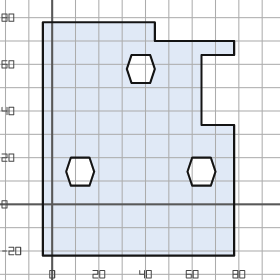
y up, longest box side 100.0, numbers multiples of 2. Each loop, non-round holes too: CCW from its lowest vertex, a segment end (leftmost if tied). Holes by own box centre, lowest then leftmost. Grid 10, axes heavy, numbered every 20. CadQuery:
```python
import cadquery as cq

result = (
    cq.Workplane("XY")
    .moveTo(-4.0, -22.0)
    .lineTo(78.0, -22.0)
    .lineTo(78.0, 34.0)
    .lineTo(64.0, 34.0)
    .lineTo(64.0, 64.0)
    .lineTo(78.0, 64.0)
    .lineTo(78.0, 70.0)
    .lineTo(44.0, 70.0)
    .lineTo(44.0, 78.0)
    .lineTo(-4.0, 78.0)
    .close()
    .moveTo(8.0, 8.0)
    .lineTo(16.0, 8.0)
    .lineTo(18.0, 14.0)
    .lineTo(16.0, 20.0)
    .lineTo(8.0, 20.0)
    .lineTo(6.0, 14.0)
    .close()
    .moveTo(60.0, 8.0)
    .lineTo(68.0, 8.0)
    .lineTo(70.0, 14.0)
    .lineTo(68.0, 20.0)
    .lineTo(60.0, 20.0)
    .lineTo(58.0, 14.0)
    .close()
    .moveTo(34.0, 52.0)
    .lineTo(42.0, 52.0)
    .lineTo(44.0, 58.0)
    .lineTo(42.0, 64.0)
    .lineTo(34.0, 64.0)
    .lineTo(32.0, 58.0)
    .close()
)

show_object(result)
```